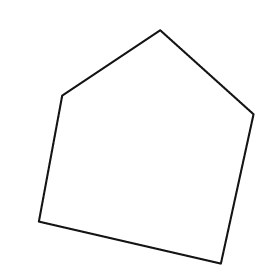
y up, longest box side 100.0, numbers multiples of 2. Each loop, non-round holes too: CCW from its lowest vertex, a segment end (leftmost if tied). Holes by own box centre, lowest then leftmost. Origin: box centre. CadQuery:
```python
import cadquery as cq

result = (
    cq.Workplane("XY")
    .moveTo(32.0, -50.0)
    .lineTo(46.0, 14.0)
    .lineTo(6.0, 50.0)
    .lineTo(-36.0, 22.0)
    .lineTo(-46.0, -32.0)
    .close()
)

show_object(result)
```